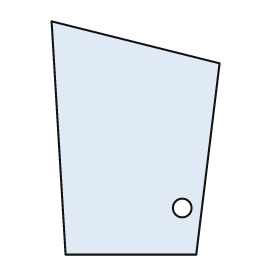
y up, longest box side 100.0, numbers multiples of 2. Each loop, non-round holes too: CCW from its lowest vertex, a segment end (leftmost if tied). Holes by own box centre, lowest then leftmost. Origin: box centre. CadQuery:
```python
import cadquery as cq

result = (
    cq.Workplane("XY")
    .moveTo(-30.0, -50.0)
    .lineTo(26.0, -50.0)
    .lineTo(36.0, 32.0)
    .lineTo(-36.0, 50.0)
    .close()
    .moveTo(20.0, -30.0)
    .circle(4.0)
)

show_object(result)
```